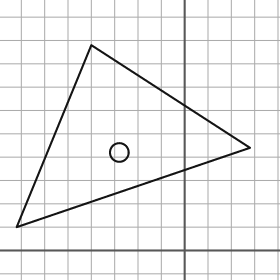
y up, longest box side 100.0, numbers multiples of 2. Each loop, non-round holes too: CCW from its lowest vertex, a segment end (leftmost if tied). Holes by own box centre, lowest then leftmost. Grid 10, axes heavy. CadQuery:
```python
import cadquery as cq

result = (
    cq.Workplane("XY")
    .moveTo(-72.0, 10.0)
    .lineTo(28.0, 44.0)
    .lineTo(-40.0, 88.0)
    .close()
    .moveTo(-28.0, 42.0)
    .circle(4.0)
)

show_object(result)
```